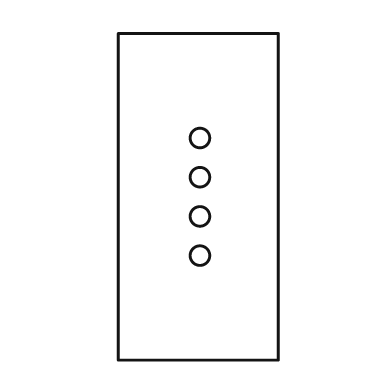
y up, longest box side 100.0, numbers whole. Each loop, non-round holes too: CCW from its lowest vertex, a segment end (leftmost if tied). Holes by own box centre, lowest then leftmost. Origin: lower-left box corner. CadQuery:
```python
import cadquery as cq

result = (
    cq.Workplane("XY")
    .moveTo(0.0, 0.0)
    .lineTo(49.0, 0.0)
    .lineTo(49.0, 100.0)
    .lineTo(0.0, 100.0)
    .close()
    .moveTo(25.0, 32.0)
    .circle(3.0)
    .moveTo(25.0, 44.0)
    .circle(3.0)
    .moveTo(25.0, 56.0)
    .circle(3.0)
    .moveTo(25.0, 68.0)
    .circle(3.0)
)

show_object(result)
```